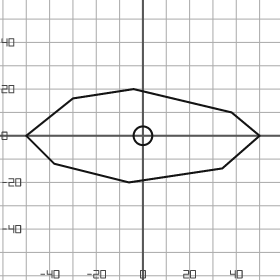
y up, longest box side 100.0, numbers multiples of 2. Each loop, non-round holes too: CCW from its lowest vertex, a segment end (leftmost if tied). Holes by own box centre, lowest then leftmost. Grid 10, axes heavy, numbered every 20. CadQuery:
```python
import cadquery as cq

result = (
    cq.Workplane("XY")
    .moveTo(-6.0, -20.0)
    .lineTo(34.0, -14.0)
    .lineTo(50.0, 0.0)
    .lineTo(38.0, 10.0)
    .lineTo(-4.0, 20.0)
    .lineTo(-30.0, 16.0)
    .lineTo(-50.0, 0.0)
    .lineTo(-38.0, -12.0)
    .close()
    .moveTo(0.0, 0.0)
    .circle(4.0)
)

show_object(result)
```